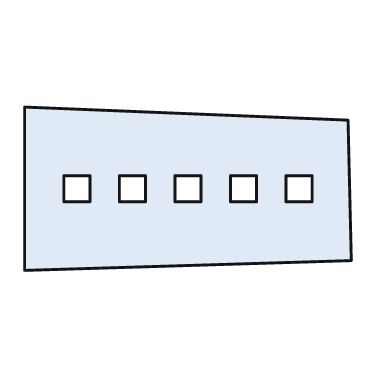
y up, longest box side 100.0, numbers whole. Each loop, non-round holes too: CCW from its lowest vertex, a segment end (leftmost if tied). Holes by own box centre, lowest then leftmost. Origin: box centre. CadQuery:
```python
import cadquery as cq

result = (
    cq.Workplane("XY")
    .moveTo(-50.0, -25.0)
    .lineTo(50.0, -22.0)
    .lineTo(49.0, 21.0)
    .lineTo(-50.0, 25.0)
    .close()
    .moveTo(-38.0, -4.0)
    .lineTo(-30.0, -4.0)
    .lineTo(-30.0, 4.0)
    .lineTo(-38.0, 4.0)
    .close()
    .moveTo(-21.0, -4.0)
    .lineTo(-13.0, -4.0)
    .lineTo(-13.0, 4.0)
    .lineTo(-21.0, 4.0)
    .close()
    .moveTo(-4.0, -4.0)
    .lineTo(4.0, -4.0)
    .lineTo(4.0, 4.0)
    .lineTo(-4.0, 4.0)
    .close()
    .moveTo(13.0, -4.0)
    .lineTo(21.0, -4.0)
    .lineTo(21.0, 4.0)
    .lineTo(13.0, 4.0)
    .close()
    .moveTo(30.0, -4.0)
    .lineTo(38.0, -4.0)
    .lineTo(38.0, 4.0)
    .lineTo(30.0, 4.0)
    .close()
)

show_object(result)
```